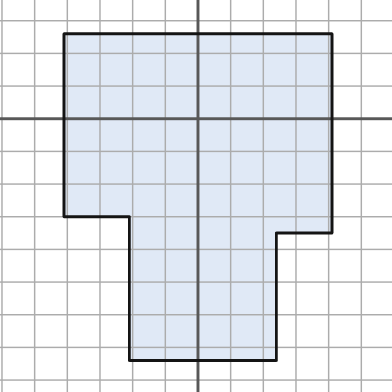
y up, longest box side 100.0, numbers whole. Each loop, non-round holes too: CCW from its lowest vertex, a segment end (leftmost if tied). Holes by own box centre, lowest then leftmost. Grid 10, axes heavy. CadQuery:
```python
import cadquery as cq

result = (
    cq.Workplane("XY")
    .moveTo(-21.0, -74.0)
    .lineTo(24.0, -74.0)
    .lineTo(24.0, -35.0)
    .lineTo(41.0, -35.0)
    .lineTo(41.0, 26.0)
    .lineTo(-41.0, 26.0)
    .lineTo(-41.0, -30.0)
    .lineTo(-21.0, -30.0)
    .close()
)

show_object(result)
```